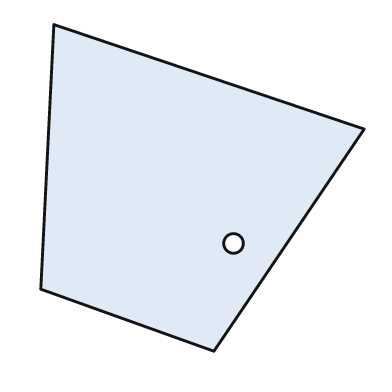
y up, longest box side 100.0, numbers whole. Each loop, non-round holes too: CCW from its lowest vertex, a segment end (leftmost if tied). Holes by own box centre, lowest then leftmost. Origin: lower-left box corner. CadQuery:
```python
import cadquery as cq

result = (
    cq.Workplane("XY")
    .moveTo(53.0, 0.0)
    .lineTo(99.0, 68.0)
    .lineTo(4.0, 100.0)
    .lineTo(0.0, 19.0)
    .close()
    .moveTo(59.0, 33.0)
    .circle(3.0)
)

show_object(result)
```